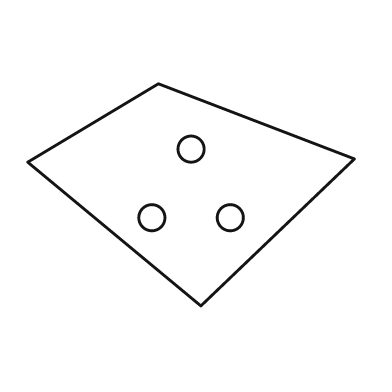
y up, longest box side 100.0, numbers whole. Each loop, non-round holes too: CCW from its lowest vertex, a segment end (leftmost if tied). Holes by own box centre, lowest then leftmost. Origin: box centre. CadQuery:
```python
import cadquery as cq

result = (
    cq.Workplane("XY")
    .moveTo(3.0, -34.0)
    .lineTo(50.0, 11.0)
    .lineTo(-10.0, 34.0)
    .lineTo(-50.0, 10.0)
    .close()
    .moveTo(-12.0, -7.0)
    .circle(4.0)
    .moveTo(12.0, -7.0)
    .circle(4.0)
    .moveTo(0.0, 14.0)
    .circle(4.0)
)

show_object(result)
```